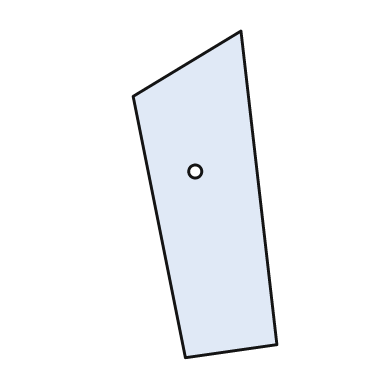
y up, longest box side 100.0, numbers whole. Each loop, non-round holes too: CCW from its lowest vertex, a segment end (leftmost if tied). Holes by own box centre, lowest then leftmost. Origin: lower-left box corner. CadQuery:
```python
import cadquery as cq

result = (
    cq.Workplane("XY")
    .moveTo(16.0, 0.0)
    .lineTo(44.0, 4.0)
    .lineTo(33.0, 100.0)
    .lineTo(0.0, 80.0)
    .close()
    .moveTo(19.0, 57.0)
    .circle(2.0)
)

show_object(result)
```